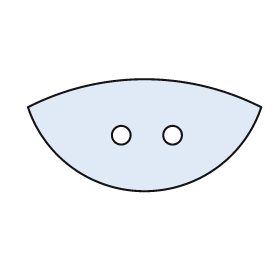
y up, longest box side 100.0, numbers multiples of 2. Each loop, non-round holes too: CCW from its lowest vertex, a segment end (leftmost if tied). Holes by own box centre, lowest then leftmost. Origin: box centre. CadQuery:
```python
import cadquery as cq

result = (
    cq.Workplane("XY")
    .moveTo(-50.0, 12.0)
    .threePointArc((0.0, -24.0), (50.0, 12.0))
    .threePointArc((0.0, 24.0), (-50.0, 12.0))
    .close()
    .moveTo(-10.0, 0.0)
    .circle(4.0)
    .moveTo(12.0, 0.0)
    .circle(4.0)
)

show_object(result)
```